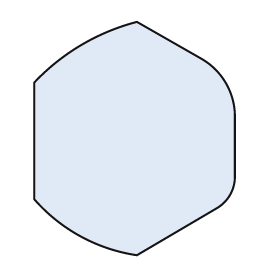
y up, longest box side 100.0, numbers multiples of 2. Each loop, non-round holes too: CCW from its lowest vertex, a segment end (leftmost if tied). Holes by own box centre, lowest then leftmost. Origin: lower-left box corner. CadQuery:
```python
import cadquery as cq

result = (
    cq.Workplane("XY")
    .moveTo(44.0, 0.0)
    .lineTo(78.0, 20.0)
    .threePointArc((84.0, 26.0), (86.0, 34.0))
    .lineTo(86.0, 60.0)
    .threePointArc((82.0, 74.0), (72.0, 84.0))
    .lineTo(44.0, 100.0)
    .threePointArc((20.0, 90.0), (0.0, 74.0))
    .lineTo(0.0, 24.0)
    .threePointArc((20.0, 8.0), (44.0, 0.0))
    .close()
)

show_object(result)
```